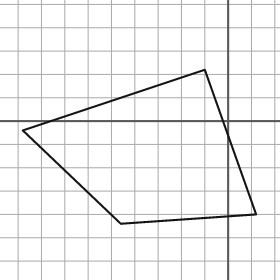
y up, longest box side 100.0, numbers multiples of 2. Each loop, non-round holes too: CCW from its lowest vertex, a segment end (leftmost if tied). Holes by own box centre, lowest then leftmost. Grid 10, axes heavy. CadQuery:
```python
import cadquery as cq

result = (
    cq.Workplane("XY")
    .moveTo(-46.0, -44.0)
    .lineTo(12.0, -40.0)
    .lineTo(-10.0, 22.0)
    .lineTo(-88.0, -4.0)
    .close()
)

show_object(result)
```